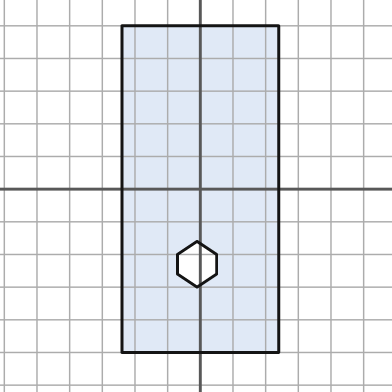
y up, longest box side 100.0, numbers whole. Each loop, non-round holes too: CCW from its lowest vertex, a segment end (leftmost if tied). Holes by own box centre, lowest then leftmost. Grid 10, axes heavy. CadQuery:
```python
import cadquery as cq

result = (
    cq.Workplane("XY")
    .moveTo(-24.0, -50.0)
    .lineTo(24.0, -50.0)
    .lineTo(24.0, 50.0)
    .lineTo(-24.0, 50.0)
    .close()
    .moveTo(-1.0, -30.0)
    .lineTo(5.0, -26.0)
    .lineTo(5.0, -20.0)
    .lineTo(-1.0, -16.0)
    .lineTo(-7.0, -20.0)
    .lineTo(-7.0, -26.0)
    .close()
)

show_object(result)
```